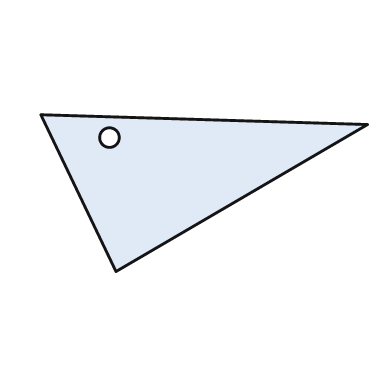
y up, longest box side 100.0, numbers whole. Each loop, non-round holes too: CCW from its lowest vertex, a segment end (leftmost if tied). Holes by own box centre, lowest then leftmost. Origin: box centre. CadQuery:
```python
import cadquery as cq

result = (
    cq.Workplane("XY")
    .moveTo(-27.0, -24.0)
    .lineTo(50.0, 21.0)
    .lineTo(-50.0, 24.0)
    .close()
    .moveTo(-29.0, 17.0)
    .circle(3.0)
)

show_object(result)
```